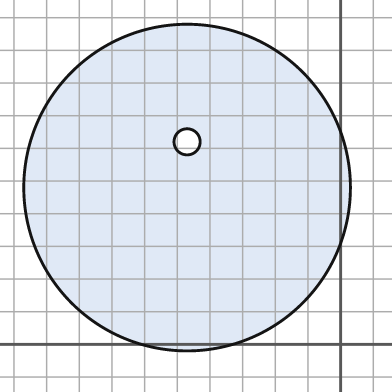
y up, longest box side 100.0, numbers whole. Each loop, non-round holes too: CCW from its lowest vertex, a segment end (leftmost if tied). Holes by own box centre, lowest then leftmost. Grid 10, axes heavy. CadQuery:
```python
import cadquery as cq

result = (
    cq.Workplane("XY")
    .moveTo(-47.0, 48.0)
    .circle(50.0)
    .moveTo(-47.0, 62.0)
    .circle(4.0)
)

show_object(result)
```